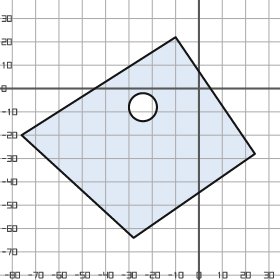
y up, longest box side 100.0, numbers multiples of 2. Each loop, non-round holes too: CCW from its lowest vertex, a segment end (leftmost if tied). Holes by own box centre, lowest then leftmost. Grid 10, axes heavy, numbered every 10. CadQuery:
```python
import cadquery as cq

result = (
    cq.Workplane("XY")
    .moveTo(-28.0, -64.0)
    .lineTo(24.0, -28.0)
    .lineTo(-10.0, 22.0)
    .lineTo(-76.0, -20.0)
    .close()
    .moveTo(-24.0, -8.0)
    .circle(6.0)
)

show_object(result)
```